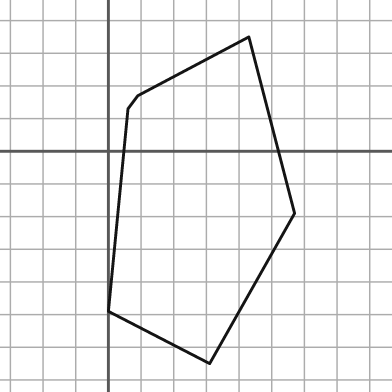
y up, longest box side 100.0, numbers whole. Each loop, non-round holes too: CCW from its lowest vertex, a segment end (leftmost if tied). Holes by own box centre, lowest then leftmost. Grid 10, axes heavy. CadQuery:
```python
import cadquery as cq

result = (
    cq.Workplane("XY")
    .moveTo(31.0, -65.0)
    .lineTo(57.0, -19.0)
    .lineTo(43.0, 35.0)
    .lineTo(9.0, 17.0)
    .lineTo(6.0, 13.0)
    .lineTo(0.0, -49.0)
    .close()
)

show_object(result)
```